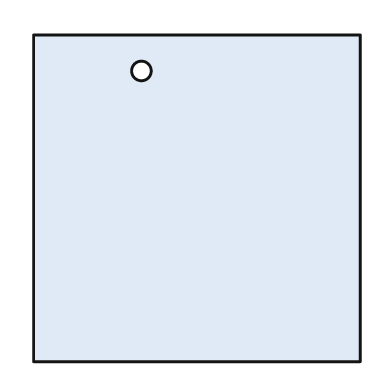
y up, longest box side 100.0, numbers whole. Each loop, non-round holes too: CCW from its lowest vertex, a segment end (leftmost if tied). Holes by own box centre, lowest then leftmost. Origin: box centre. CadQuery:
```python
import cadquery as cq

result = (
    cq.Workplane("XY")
    .moveTo(-50.0, -50.0)
    .lineTo(50.0, -50.0)
    .lineTo(50.0, 50.0)
    .lineTo(-50.0, 50.0)
    .close()
    .moveTo(-17.0, 39.0)
    .circle(3.0)
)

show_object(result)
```